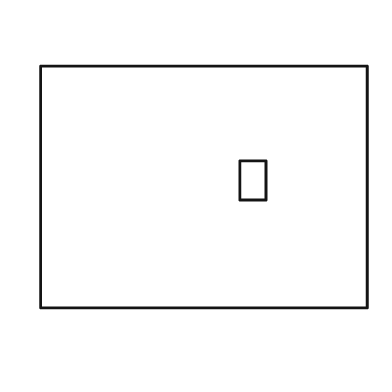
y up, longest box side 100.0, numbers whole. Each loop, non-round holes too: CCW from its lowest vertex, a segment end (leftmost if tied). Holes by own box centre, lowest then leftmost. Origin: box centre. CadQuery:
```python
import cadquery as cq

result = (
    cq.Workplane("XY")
    .moveTo(-50.0, -37.0)
    .lineTo(50.0, -37.0)
    .lineTo(50.0, 37.0)
    .lineTo(-50.0, 37.0)
    .close()
    .moveTo(11.0, -4.0)
    .lineTo(19.0, -4.0)
    .lineTo(19.0, 8.0)
    .lineTo(11.0, 8.0)
    .close()
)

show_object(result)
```